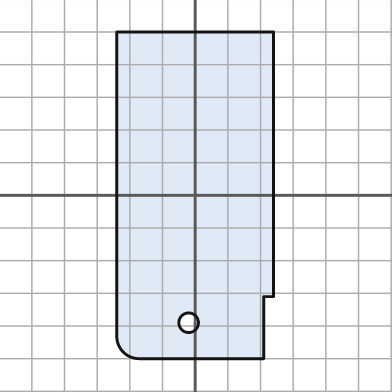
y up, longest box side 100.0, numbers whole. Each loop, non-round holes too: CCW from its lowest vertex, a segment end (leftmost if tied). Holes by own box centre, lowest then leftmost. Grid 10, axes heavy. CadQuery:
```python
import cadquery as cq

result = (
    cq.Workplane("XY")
    .moveTo(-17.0, -50.0)
    .lineTo(21.0, -50.0)
    .lineTo(21.0, -31.0)
    .lineTo(24.0, -31.0)
    .lineTo(24.0, 50.0)
    .lineTo(-24.0, 50.0)
    .lineTo(-24.0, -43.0)
    .threePointArc((-22.0, -48.0), (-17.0, -50.0))
    .close()
    .moveTo(-2.0, -39.0)
    .circle(3.0)
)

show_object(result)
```